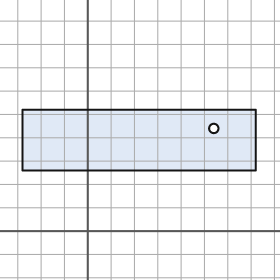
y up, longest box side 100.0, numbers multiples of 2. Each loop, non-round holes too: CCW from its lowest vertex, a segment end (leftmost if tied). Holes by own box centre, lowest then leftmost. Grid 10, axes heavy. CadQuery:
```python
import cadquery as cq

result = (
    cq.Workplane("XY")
    .moveTo(-28.0, 26.0)
    .lineTo(72.0, 26.0)
    .lineTo(72.0, 52.0)
    .lineTo(-28.0, 52.0)
    .close()
    .moveTo(54.0, 44.0)
    .circle(2.0)
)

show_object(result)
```